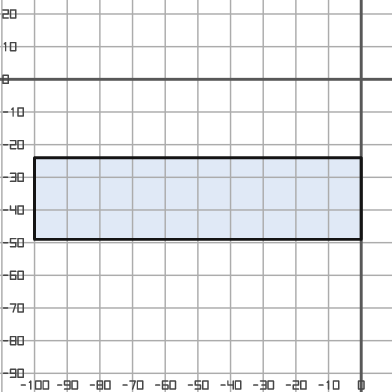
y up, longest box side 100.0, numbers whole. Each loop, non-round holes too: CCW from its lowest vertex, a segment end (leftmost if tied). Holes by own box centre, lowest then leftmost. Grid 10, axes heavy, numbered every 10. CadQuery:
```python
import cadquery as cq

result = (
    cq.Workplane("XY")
    .moveTo(-100.0, -49.0)
    .lineTo(0.0, -49.0)
    .lineTo(0.0, -24.0)
    .lineTo(-100.0, -24.0)
    .close()
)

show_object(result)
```